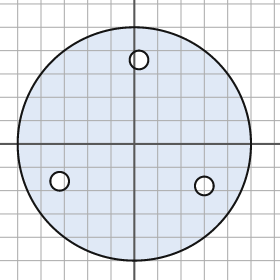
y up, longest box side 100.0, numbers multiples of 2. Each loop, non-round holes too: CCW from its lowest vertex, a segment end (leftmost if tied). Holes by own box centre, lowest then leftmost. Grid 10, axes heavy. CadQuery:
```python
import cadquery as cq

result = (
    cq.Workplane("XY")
    .moveTo(0.0, 0.0)
    .circle(50.0)
    .moveTo(30.0, -18.0)
    .circle(4.0)
    .moveTo(-32.0, -16.0)
    .circle(4.0)
    .moveTo(2.0, 36.0)
    .circle(4.0)
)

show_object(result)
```